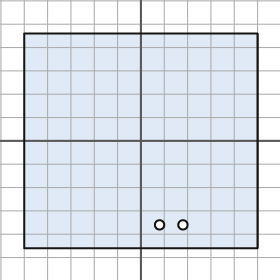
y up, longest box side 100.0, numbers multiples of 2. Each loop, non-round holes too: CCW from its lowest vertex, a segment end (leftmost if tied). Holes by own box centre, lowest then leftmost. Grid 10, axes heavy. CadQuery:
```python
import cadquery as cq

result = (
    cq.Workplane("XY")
    .moveTo(-50.0, -46.0)
    .lineTo(50.0, -46.0)
    .lineTo(50.0, 46.0)
    .lineTo(-50.0, 46.0)
    .close()
    .moveTo(8.0, -36.0)
    .circle(2.0)
    .moveTo(18.0, -36.0)
    .circle(2.0)
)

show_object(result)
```